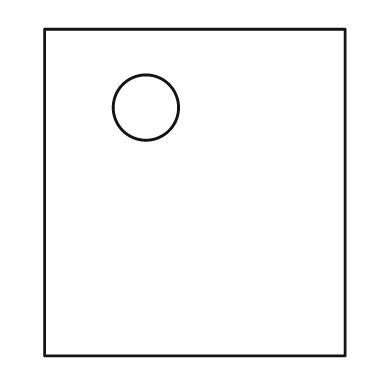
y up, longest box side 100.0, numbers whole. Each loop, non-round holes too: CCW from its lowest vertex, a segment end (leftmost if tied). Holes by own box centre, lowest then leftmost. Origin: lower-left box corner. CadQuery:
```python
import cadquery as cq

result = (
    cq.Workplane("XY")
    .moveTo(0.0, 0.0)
    .lineTo(92.0, 0.0)
    .lineTo(92.0, 100.0)
    .lineTo(0.0, 100.0)
    .close()
    .moveTo(31.0, 76.0)
    .circle(10.0)
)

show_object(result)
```